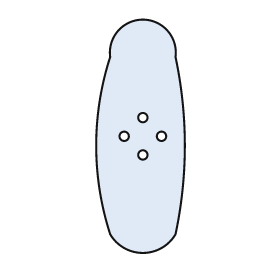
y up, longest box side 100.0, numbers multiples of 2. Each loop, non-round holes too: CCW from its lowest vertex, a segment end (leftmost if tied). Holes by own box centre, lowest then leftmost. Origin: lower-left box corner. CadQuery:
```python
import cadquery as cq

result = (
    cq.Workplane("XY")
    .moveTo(6.0, 8.0)
    .threePointArc((20.0, 0.0), (34.0, 8.0))
    .threePointArc((38.0, 46.0), (34.0, 84.0))
    .threePointArc((20.0, 100.0), (6.0, 84.0))
    .threePointArc((0.0, 46.0), (6.0, 8.0))
    .close()
    .moveTo(20.0, 42.0)
    .circle(2.0)
    .moveTo(12.0, 50.0)
    .circle(2.0)
    .moveTo(28.0, 50.0)
    .circle(2.0)
    .moveTo(20.0, 58.0)
    .circle(2.0)
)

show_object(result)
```